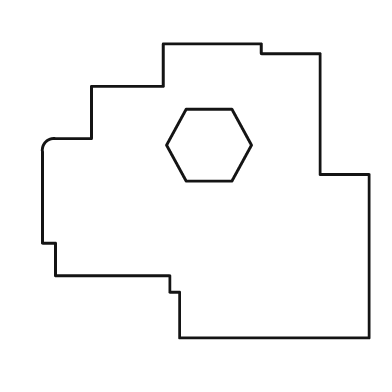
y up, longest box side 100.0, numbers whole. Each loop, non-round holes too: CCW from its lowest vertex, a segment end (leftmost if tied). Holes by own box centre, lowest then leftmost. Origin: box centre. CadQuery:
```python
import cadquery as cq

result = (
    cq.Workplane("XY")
    .moveTo(-8.0, -45.0)
    .lineTo(50.0, -45.0)
    .lineTo(50.0, 5.0)
    .lineTo(35.0, 5.0)
    .lineTo(35.0, 42.0)
    .lineTo(17.0, 42.0)
    .lineTo(17.0, 45.0)
    .lineTo(-13.0, 45.0)
    .lineTo(-13.0, 32.0)
    .lineTo(-35.0, 32.0)
    .lineTo(-35.0, 16.0)
    .lineTo(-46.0, 16.0)
    .threePointArc((-49.0, 15.0), (-50.0, 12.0))
    .lineTo(-50.0, -16.0)
    .lineTo(-46.0, -16.0)
    .lineTo(-46.0, -26.0)
    .lineTo(-11.0, -26.0)
    .lineTo(-11.0, -31.0)
    .lineTo(-8.0, -31.0)
    .close()
    .moveTo(-6.0, 3.0)
    .lineTo(8.0, 3.0)
    .lineTo(14.0, 14.0)
    .lineTo(8.0, 25.0)
    .lineTo(-6.0, 25.0)
    .lineTo(-12.0, 14.0)
    .close()
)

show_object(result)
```